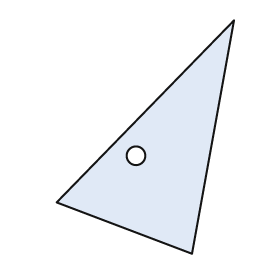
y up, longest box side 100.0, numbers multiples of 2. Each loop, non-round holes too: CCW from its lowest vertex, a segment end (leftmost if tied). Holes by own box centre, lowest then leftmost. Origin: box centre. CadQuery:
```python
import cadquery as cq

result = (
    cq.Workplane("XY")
    .moveTo(20.0, -50.0)
    .lineTo(38.0, 50.0)
    .lineTo(-38.0, -28.0)
    .close()
    .moveTo(-4.0, -8.0)
    .circle(4.0)
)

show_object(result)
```